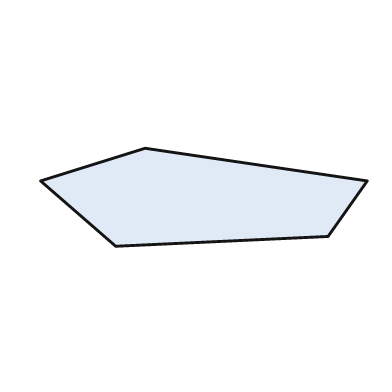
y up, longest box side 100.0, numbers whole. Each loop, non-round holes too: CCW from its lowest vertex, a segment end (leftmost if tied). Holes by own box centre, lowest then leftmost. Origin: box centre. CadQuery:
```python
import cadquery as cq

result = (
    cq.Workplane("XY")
    .moveTo(-27.0, -15.0)
    .lineTo(38.0, -12.0)
    .lineTo(50.0, 5.0)
    .lineTo(-18.0, 15.0)
    .lineTo(-50.0, 5.0)
    .close()
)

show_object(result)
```